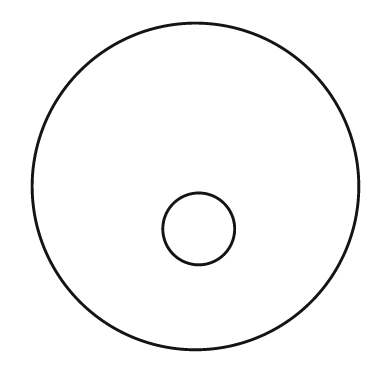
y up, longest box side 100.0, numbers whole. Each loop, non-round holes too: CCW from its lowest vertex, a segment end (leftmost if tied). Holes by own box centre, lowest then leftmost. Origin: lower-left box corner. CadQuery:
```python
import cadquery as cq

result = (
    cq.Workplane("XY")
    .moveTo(50.0, 50.0)
    .circle(50.0)
    .moveTo(51.0, 37.0)
    .circle(11.0)
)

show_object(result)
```